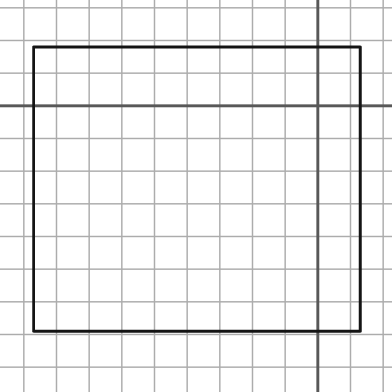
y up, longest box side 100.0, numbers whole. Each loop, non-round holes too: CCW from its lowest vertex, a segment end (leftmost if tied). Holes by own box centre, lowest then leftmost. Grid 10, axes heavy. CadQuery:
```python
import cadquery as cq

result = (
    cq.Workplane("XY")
    .moveTo(-87.0, -69.0)
    .lineTo(13.0, -69.0)
    .lineTo(13.0, 18.0)
    .lineTo(-87.0, 18.0)
    .close()
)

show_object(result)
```